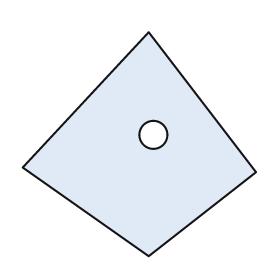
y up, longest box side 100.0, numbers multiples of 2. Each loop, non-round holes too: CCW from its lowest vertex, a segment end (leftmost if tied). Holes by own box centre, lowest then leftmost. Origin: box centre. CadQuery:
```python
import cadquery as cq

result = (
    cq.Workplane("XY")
    .moveTo(4.0, -48.0)
    .lineTo(50.0, -12.0)
    .lineTo(4.0, 48.0)
    .lineTo(-50.0, -10.0)
    .close()
    .moveTo(6.0, 4.0)
    .circle(6.0)
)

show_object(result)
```